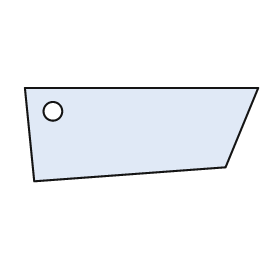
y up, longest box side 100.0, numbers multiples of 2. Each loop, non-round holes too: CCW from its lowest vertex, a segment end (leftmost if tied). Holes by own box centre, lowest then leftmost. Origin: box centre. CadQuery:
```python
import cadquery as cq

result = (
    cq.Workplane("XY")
    .moveTo(-46.0, -20.0)
    .lineTo(36.0, -14.0)
    .lineTo(50.0, 20.0)
    .lineTo(-50.0, 20.0)
    .close()
    .moveTo(-38.0, 10.0)
    .circle(4.0)
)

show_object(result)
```